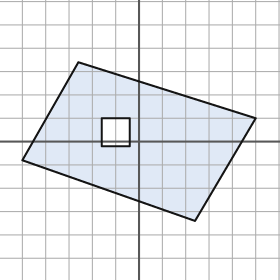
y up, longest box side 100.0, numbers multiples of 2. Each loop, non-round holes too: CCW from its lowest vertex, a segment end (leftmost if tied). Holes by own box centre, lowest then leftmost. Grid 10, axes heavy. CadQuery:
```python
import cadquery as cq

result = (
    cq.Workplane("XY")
    .moveTo(24.0, -34.0)
    .lineTo(50.0, 10.0)
    .lineTo(-26.0, 34.0)
    .lineTo(-50.0, -8.0)
    .close()
    .moveTo(-16.0, -2.0)
    .lineTo(-4.0, -2.0)
    .lineTo(-4.0, 10.0)
    .lineTo(-16.0, 10.0)
    .close()
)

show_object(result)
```